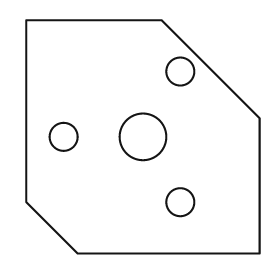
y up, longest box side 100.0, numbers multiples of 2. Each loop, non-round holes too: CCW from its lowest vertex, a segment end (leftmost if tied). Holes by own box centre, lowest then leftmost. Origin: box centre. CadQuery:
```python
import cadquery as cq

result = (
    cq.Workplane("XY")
    .moveTo(-28.0, -50.0)
    .lineTo(50.0, -50.0)
    .lineTo(50.0, 8.0)
    .lineTo(8.0, 50.0)
    .lineTo(-50.0, 50.0)
    .lineTo(-50.0, -28.0)
    .close()
    .moveTo(16.0, -28.0)
    .circle(6.0)
    .moveTo(-34.0, 0.0)
    .circle(6.0)
    .moveTo(0.0, 0.0)
    .circle(10.0)
    .moveTo(16.0, 28.0)
    .circle(6.0)
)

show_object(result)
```